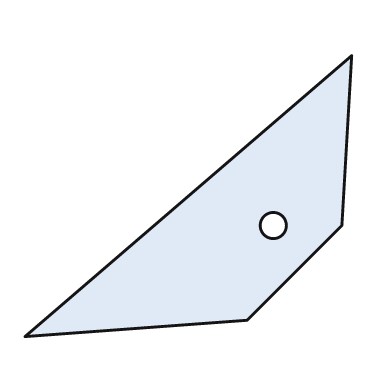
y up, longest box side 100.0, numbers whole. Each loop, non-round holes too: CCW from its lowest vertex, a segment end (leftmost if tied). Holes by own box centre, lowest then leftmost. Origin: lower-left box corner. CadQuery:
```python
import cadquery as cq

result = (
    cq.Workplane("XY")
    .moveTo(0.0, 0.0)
    .lineTo(68.0, 5.0)
    .lineTo(97.0, 34.0)
    .lineTo(100.0, 86.0)
    .close()
    .moveTo(76.0, 34.0)
    .circle(4.0)
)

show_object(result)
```